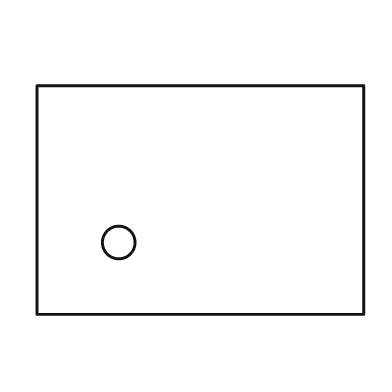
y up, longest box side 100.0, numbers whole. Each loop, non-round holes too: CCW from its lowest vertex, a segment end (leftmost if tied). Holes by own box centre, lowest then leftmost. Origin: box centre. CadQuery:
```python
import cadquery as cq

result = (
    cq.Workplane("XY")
    .moveTo(-50.0, -35.0)
    .lineTo(50.0, -35.0)
    .lineTo(50.0, 35.0)
    .lineTo(-50.0, 35.0)
    .close()
    .moveTo(-25.0, -13.0)
    .circle(5.0)
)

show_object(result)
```